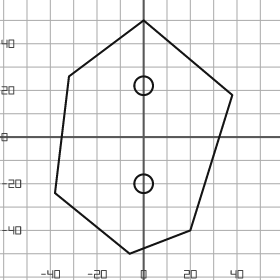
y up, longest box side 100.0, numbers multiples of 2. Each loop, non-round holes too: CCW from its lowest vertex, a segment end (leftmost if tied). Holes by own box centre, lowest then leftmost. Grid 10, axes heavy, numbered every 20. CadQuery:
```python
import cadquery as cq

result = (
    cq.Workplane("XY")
    .moveTo(-6.0, -50.0)
    .lineTo(20.0, -40.0)
    .lineTo(38.0, 18.0)
    .lineTo(0.0, 50.0)
    .lineTo(-32.0, 26.0)
    .lineTo(-38.0, -24.0)
    .close()
    .moveTo(0.0, -20.0)
    .circle(4.0)
    .moveTo(0.0, 22.0)
    .circle(4.0)
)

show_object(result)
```